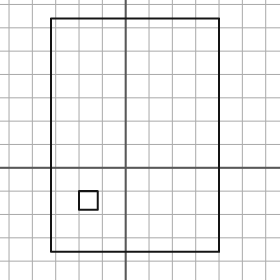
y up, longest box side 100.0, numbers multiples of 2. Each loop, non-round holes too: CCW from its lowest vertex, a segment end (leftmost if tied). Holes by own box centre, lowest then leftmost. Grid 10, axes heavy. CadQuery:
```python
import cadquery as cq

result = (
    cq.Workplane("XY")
    .moveTo(-32.0, -36.0)
    .lineTo(40.0, -36.0)
    .lineTo(40.0, 64.0)
    .lineTo(-32.0, 64.0)
    .close()
    .moveTo(-20.0, -18.0)
    .lineTo(-12.0, -18.0)
    .lineTo(-12.0, -10.0)
    .lineTo(-20.0, -10.0)
    .close()
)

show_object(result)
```